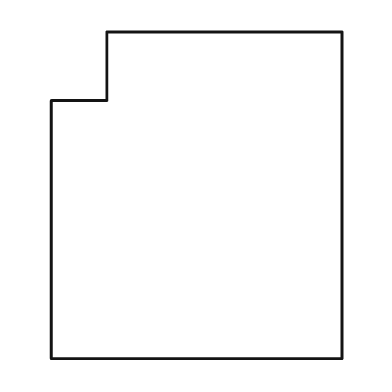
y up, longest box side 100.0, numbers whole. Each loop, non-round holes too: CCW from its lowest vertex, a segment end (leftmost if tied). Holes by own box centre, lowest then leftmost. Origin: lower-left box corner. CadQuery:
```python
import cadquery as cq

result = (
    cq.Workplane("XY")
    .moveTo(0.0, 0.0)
    .lineTo(89.0, 0.0)
    .lineTo(89.0, 100.0)
    .lineTo(17.0, 100.0)
    .lineTo(17.0, 79.0)
    .lineTo(0.0, 79.0)
    .close()
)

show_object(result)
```